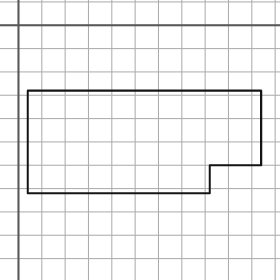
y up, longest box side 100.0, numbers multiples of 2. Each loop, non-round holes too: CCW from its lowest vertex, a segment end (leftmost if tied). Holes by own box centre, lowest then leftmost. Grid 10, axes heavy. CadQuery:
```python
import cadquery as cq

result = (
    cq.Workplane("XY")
    .moveTo(4.0, -72.0)
    .lineTo(82.0, -72.0)
    .lineTo(82.0, -60.0)
    .lineTo(104.0, -60.0)
    .lineTo(104.0, -28.0)
    .lineTo(4.0, -28.0)
    .close()
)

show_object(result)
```